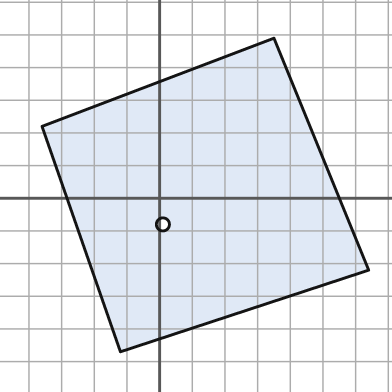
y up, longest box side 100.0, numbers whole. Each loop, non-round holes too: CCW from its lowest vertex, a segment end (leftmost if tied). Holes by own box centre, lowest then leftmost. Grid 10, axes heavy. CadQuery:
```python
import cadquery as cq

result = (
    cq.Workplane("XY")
    .moveTo(-12.0, -47.0)
    .lineTo(64.0, -22.0)
    .lineTo(35.0, 49.0)
    .lineTo(-36.0, 22.0)
    .close()
    .moveTo(1.0, -8.0)
    .circle(2.0)
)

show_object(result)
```